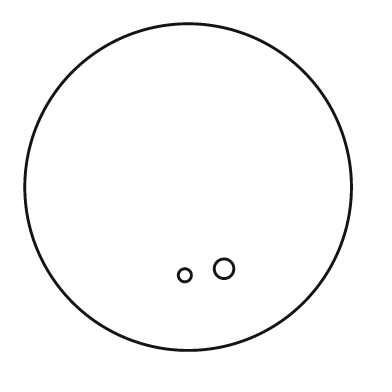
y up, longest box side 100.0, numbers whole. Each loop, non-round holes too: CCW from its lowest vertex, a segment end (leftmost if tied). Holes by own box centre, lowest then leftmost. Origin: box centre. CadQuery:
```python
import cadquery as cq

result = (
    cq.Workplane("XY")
    .moveTo(0.0, 0.0)
    .circle(50.0)
    .moveTo(-1.0, -27.0)
    .circle(2.0)
    .moveTo(11.0, -25.0)
    .circle(3.0)
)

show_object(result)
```